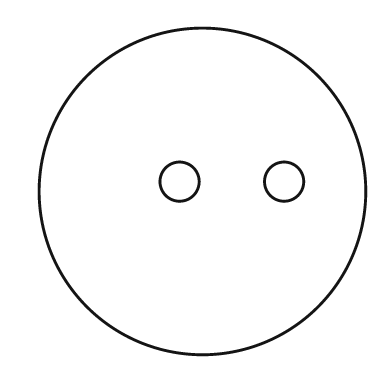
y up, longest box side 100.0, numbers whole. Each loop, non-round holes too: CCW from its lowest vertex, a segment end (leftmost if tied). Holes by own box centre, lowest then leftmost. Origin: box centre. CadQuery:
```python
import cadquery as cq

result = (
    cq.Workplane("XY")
    .moveTo(0.0, 0.0)
    .circle(50.0)
    .moveTo(-7.0, 3.0)
    .circle(6.0)
    .moveTo(25.0, 3.0)
    .circle(6.0)
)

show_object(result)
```